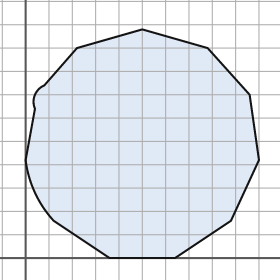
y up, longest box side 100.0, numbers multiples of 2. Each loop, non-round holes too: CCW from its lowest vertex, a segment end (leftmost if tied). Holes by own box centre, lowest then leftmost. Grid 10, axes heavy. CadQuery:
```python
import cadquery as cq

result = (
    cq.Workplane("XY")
    .moveTo(36.0, 0.0)
    .lineTo(64.0, 0.0)
    .lineTo(88.0, 16.0)
    .lineTo(100.0, 42.0)
    .lineTo(96.0, 70.0)
    .lineTo(78.0, 90.0)
    .lineTo(50.0, 98.0)
    .lineTo(22.0, 90.0)
    .lineTo(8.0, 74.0)
    .threePointArc((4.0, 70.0), (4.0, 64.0))
    .lineTo(0.0, 42.0)
    .threePointArc((4.0, 28.0), (12.0, 16.0))
    .close()
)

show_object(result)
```